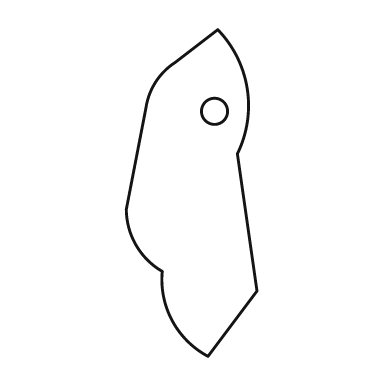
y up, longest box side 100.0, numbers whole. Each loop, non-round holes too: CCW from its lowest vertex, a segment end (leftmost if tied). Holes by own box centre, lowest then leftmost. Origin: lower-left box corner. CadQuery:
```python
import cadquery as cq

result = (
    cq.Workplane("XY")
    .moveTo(25.0, 0.0)
    .lineTo(40.0, 20.0)
    .lineTo(34.0, 62.0)
    .threePointArc((37.0, 82.0), (28.0, 100.0))
    .lineTo(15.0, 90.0)
    .threePointArc((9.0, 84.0), (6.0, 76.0))
    .lineTo(0.0, 45.0)
    .threePointArc((3.0, 34.0), (11.0, 26.0))
    .threePointArc((14.0, 11.0), (25.0, 0.0))
    .close()
    .moveTo(27.0, 75.0)
    .circle(4.0)
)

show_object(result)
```